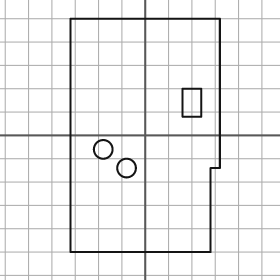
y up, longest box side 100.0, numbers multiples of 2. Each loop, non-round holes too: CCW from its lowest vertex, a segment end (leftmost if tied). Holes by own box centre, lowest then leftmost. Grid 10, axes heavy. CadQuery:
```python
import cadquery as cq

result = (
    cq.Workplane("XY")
    .moveTo(-32.0, -50.0)
    .lineTo(28.0, -50.0)
    .lineTo(28.0, -14.0)
    .lineTo(32.0, -14.0)
    .lineTo(32.0, 50.0)
    .lineTo(-32.0, 50.0)
    .close()
    .moveTo(-8.0, -14.0)
    .circle(4.0)
    .moveTo(-18.0, -6.0)
    .circle(4.0)
    .moveTo(16.0, 8.0)
    .lineTo(24.0, 8.0)
    .lineTo(24.0, 20.0)
    .lineTo(16.0, 20.0)
    .close()
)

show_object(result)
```